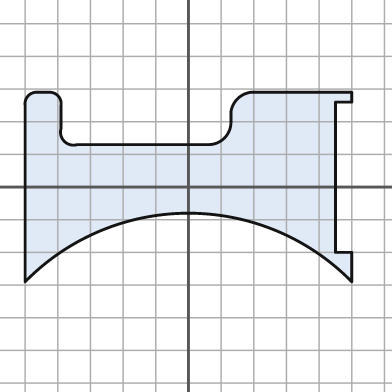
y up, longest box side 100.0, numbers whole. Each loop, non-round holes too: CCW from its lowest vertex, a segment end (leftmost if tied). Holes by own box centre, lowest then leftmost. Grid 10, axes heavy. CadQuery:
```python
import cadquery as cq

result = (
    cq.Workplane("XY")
    .moveTo(-50.0, -29.0)
    .threePointArc((0.0, -8.0), (50.0, -29.0))
    .lineTo(50.0, -20.0)
    .lineTo(45.0, -20.0)
    .lineTo(45.0, 26.0)
    .lineTo(50.0, 26.0)
    .lineTo(50.0, 29.0)
    .lineTo(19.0, 29.0)
    .threePointArc((15.0, 27.0), (13.0, 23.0))
    .lineTo(13.0, 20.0)
    .threePointArc((11.0, 15.0), (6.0, 13.0))
    .lineTo(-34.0, 13.0)
    .threePointArc((-38.0, 14.0), (-39.0, 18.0))
    .lineTo(-39.0, 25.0)
    .threePointArc((-40.0, 28.0), (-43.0, 29.0))
    .lineTo(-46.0, 29.0)
    .threePointArc((-49.0, 28.0), (-50.0, 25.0))
    .close()
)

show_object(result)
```